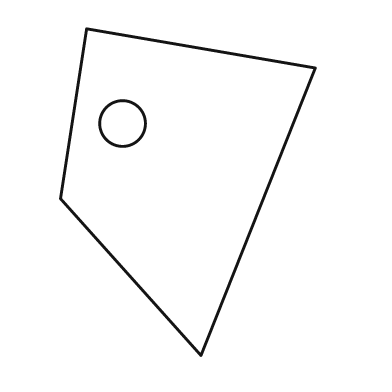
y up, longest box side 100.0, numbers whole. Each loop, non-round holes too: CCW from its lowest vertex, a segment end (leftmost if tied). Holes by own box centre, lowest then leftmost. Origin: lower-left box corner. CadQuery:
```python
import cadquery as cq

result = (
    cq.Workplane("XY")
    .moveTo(43.0, 0.0)
    .lineTo(78.0, 88.0)
    .lineTo(8.0, 100.0)
    .lineTo(0.0, 48.0)
    .close()
    .moveTo(19.0, 71.0)
    .circle(7.0)
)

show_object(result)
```